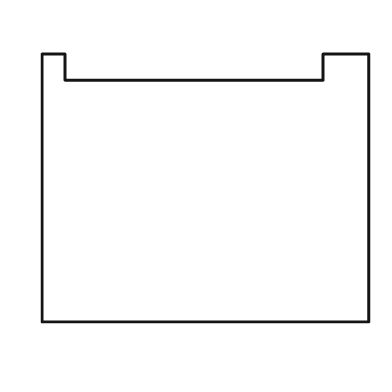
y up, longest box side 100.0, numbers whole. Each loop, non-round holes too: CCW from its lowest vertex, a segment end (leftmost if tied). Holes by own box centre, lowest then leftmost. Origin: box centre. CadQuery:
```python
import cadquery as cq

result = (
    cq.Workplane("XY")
    .moveTo(-50.0, -41.0)
    .lineTo(50.0, -41.0)
    .lineTo(50.0, 41.0)
    .lineTo(36.0, 41.0)
    .lineTo(36.0, 33.0)
    .lineTo(-43.0, 33.0)
    .lineTo(-43.0, 41.0)
    .lineTo(-50.0, 41.0)
    .close()
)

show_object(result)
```